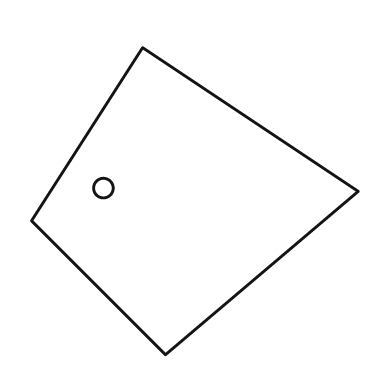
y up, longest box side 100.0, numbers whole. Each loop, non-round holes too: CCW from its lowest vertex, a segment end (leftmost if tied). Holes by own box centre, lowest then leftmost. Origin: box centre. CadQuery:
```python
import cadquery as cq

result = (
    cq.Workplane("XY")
    .moveTo(-9.0, -47.0)
    .lineTo(50.0, 3.0)
    .lineTo(-16.0, 47.0)
    .lineTo(-50.0, -6.0)
    .close()
    .moveTo(-28.0, 4.0)
    .circle(3.0)
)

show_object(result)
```